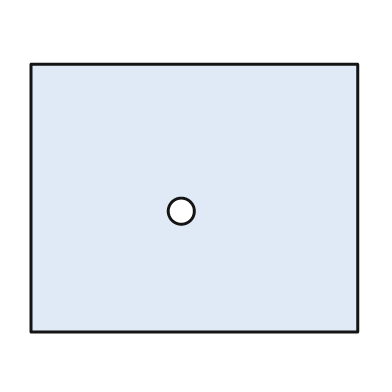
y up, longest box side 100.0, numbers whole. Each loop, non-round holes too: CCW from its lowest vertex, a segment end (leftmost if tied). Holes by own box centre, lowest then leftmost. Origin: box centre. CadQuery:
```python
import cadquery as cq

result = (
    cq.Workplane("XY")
    .moveTo(-50.0, -41.0)
    .lineTo(50.0, -41.0)
    .lineTo(50.0, 41.0)
    .lineTo(-50.0, 41.0)
    .close()
    .moveTo(-4.0, -4.0)
    .circle(4.0)
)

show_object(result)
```